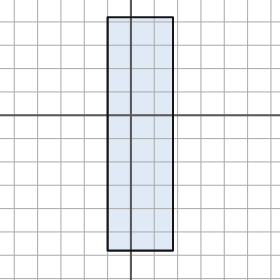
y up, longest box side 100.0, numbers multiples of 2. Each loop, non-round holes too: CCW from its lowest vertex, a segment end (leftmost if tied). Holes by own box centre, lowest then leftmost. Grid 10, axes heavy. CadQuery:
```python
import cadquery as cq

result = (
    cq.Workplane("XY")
    .moveTo(-10.0, -58.0)
    .lineTo(18.0, -58.0)
    .lineTo(18.0, 42.0)
    .lineTo(-10.0, 42.0)
    .close()
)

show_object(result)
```